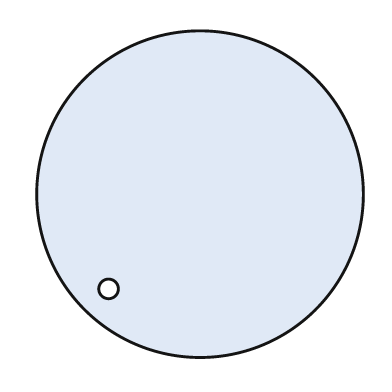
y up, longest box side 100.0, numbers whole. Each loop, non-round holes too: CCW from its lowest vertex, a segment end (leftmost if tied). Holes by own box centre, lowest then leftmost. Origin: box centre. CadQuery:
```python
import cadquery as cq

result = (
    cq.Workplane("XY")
    .moveTo(0.0, 0.0)
    .circle(50.0)
    .moveTo(-28.0, -29.0)
    .circle(3.0)
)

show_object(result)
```